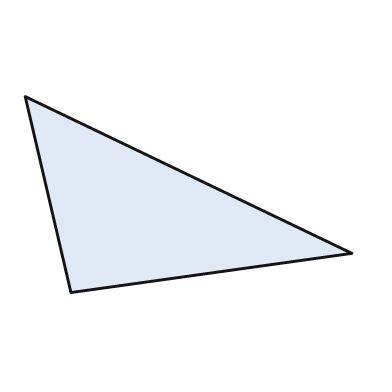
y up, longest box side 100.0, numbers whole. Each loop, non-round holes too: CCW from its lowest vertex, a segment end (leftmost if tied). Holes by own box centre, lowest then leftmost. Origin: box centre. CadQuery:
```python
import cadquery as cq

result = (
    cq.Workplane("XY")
    .moveTo(-36.0, -30.0)
    .lineTo(50.0, -18.0)
    .lineTo(-50.0, 30.0)
    .close()
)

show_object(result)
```